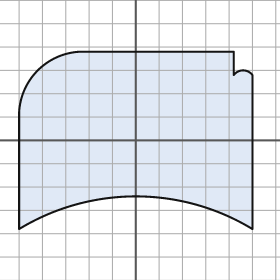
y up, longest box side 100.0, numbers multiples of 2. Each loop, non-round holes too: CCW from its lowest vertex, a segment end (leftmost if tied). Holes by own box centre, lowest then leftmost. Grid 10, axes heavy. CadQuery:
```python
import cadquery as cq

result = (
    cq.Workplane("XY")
    .moveTo(-50.0, -38.0)
    .threePointArc((0.0, -24.0), (50.0, -38.0))
    .lineTo(50.0, 28.0)
    .threePointArc((46.0, 30.0), (42.0, 28.0))
    .lineTo(42.0, 38.0)
    .lineTo(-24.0, 38.0)
    .threePointArc((-42.0, 30.0), (-50.0, 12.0))
    .close()
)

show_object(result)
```